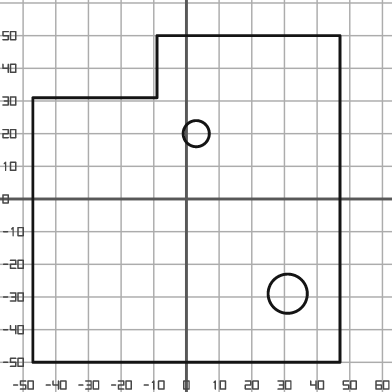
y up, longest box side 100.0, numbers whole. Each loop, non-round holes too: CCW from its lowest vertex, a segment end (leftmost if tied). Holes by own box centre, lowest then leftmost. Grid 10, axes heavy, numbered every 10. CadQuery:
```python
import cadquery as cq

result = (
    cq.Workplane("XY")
    .moveTo(-47.0, -50.0)
    .lineTo(47.0, -50.0)
    .lineTo(47.0, 50.0)
    .lineTo(-9.0, 50.0)
    .lineTo(-9.0, 31.0)
    .lineTo(-47.0, 31.0)
    .close()
    .moveTo(31.0, -29.0)
    .circle(6.0)
    .moveTo(3.0, 20.0)
    .circle(4.0)
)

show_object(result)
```